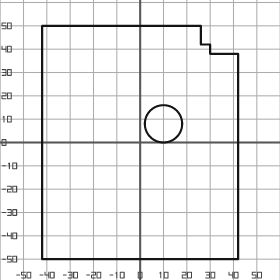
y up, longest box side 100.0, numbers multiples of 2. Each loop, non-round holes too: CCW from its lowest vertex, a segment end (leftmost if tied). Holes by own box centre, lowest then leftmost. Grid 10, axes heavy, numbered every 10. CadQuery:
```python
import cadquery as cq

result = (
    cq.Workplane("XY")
    .moveTo(-42.0, -50.0)
    .lineTo(42.0, -50.0)
    .lineTo(42.0, 38.0)
    .lineTo(30.0, 38.0)
    .lineTo(30.0, 42.0)
    .lineTo(26.0, 42.0)
    .lineTo(26.0, 50.0)
    .lineTo(-42.0, 50.0)
    .close()
    .moveTo(10.0, 8.0)
    .circle(8.0)
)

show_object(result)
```